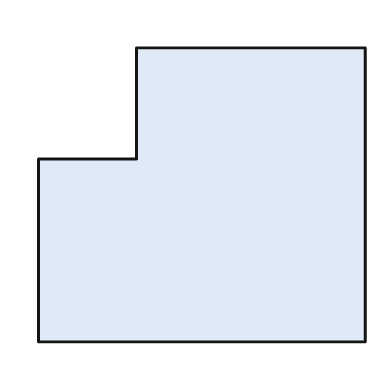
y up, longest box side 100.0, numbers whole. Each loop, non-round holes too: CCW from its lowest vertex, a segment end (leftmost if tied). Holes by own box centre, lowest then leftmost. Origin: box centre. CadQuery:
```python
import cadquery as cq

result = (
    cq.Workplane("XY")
    .moveTo(-50.0, -45.0)
    .lineTo(50.0, -45.0)
    .lineTo(50.0, 45.0)
    .lineTo(-20.0, 45.0)
    .lineTo(-20.0, 11.0)
    .lineTo(-50.0, 11.0)
    .close()
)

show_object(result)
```